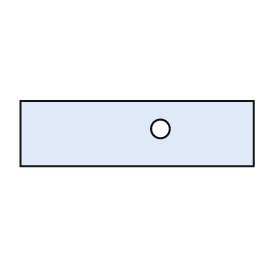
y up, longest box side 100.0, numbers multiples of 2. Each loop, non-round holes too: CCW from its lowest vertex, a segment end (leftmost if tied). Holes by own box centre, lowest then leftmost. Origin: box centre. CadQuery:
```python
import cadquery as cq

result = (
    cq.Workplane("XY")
    .moveTo(-50.0, -14.0)
    .lineTo(50.0, -14.0)
    .lineTo(50.0, 14.0)
    .lineTo(-50.0, 14.0)
    .close()
    .moveTo(10.0, 2.0)
    .circle(4.0)
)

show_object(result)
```